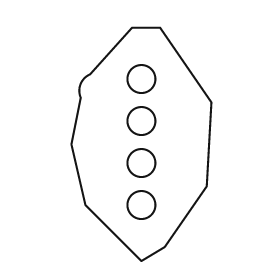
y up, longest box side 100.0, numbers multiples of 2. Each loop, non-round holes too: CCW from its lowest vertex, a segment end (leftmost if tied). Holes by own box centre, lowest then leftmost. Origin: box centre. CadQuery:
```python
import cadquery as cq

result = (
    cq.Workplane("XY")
    .moveTo(0.0, -50.0)
    .lineTo(10.0, -44.0)
    .lineTo(28.0, -18.0)
    .lineTo(30.0, 18.0)
    .lineTo(8.0, 50.0)
    .lineTo(-4.0, 50.0)
    .lineTo(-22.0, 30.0)
    .threePointArc((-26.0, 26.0), (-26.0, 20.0))
    .lineTo(-30.0, 0.0)
    .lineTo(-24.0, -26.0)
    .close()
    .moveTo(0.0, -26.0)
    .circle(6.0)
    .moveTo(0.0, -8.0)
    .circle(6.0)
    .moveTo(0.0, 10.0)
    .circle(6.0)
    .moveTo(0.0, 28.0)
    .circle(6.0)
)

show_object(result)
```